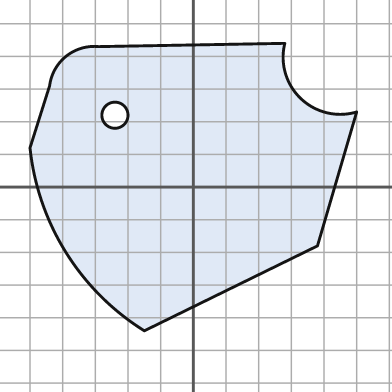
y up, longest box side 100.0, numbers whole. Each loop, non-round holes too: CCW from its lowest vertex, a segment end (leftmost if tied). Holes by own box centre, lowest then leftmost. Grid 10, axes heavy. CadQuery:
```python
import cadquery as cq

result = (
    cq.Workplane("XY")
    .moveTo(-15.0, -44.0)
    .lineTo(38.0, -18.0)
    .lineTo(50.0, 23.0)
    .threePointArc((33.0, 27.0), (28.0, 44.0))
    .lineTo(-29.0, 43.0)
    .threePointArc((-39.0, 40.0), (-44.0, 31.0))
    .lineTo(-50.0, 12.0)
    .threePointArc((-39.0, -20.0), (-15.0, -44.0))
    .close()
    .moveTo(-24.0, 22.0)
    .circle(4.0)
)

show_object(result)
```